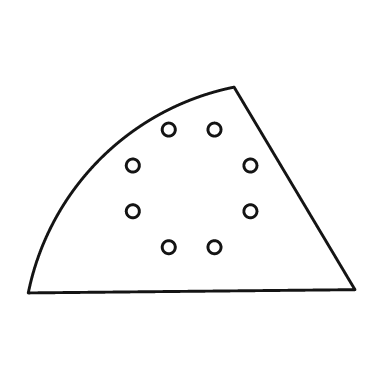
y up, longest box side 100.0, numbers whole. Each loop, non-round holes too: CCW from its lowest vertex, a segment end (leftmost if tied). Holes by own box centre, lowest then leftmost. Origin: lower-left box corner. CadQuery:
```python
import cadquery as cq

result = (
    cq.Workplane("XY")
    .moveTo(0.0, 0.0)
    .lineTo(100.0, 1.0)
    .lineTo(63.0, 63.0)
    .threePointArc((22.0, 41.0), (0.0, 0.0))
    .close()
    .moveTo(43.0, 14.0)
    .circle(2.0)
    .moveTo(57.0, 14.0)
    .circle(2.0)
    .moveTo(32.0, 25.0)
    .circle(2.0)
    .moveTo(68.0, 25.0)
    .circle(2.0)
    .moveTo(32.0, 39.0)
    .circle(2.0)
    .moveTo(68.0, 39.0)
    .circle(2.0)
    .moveTo(43.0, 50.0)
    .circle(2.0)
    .moveTo(57.0, 50.0)
    .circle(2.0)
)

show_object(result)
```